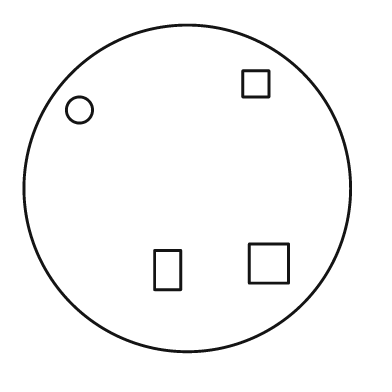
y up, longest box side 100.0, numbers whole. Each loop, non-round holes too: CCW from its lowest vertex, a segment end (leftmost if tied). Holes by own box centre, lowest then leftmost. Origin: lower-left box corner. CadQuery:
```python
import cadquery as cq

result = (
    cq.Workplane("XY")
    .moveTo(50.0, 50.0)
    .circle(50.0)
    .moveTo(40.0, 19.0)
    .lineTo(48.0, 19.0)
    .lineTo(48.0, 31.0)
    .lineTo(40.0, 31.0)
    .close()
    .moveTo(69.0, 21.0)
    .lineTo(81.0, 21.0)
    .lineTo(81.0, 33.0)
    .lineTo(69.0, 33.0)
    .close()
    .moveTo(17.0, 74.0)
    .circle(4.0)
    .moveTo(67.0, 78.0)
    .lineTo(75.0, 78.0)
    .lineTo(75.0, 86.0)
    .lineTo(67.0, 86.0)
    .close()
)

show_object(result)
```